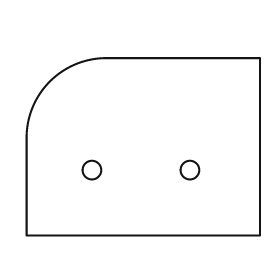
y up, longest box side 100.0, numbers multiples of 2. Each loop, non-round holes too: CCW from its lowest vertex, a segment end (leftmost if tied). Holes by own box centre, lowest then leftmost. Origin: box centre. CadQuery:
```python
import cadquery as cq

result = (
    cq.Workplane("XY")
    .moveTo(-50.0, -38.0)
    .lineTo(50.0, -38.0)
    .lineTo(50.0, 38.0)
    .lineTo(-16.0, 38.0)
    .threePointArc((-40.0, 28.0), (-50.0, 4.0))
    .close()
    .moveTo(-22.0, -10.0)
    .circle(4.0)
    .moveTo(20.0, -10.0)
    .circle(4.0)
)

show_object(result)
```